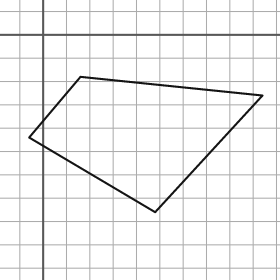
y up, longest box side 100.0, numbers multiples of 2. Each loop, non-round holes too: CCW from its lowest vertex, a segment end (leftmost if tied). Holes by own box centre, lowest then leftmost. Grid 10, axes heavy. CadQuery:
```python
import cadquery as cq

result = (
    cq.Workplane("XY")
    .moveTo(48.0, -76.0)
    .lineTo(94.0, -26.0)
    .lineTo(16.0, -18.0)
    .lineTo(-6.0, -44.0)
    .close()
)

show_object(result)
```